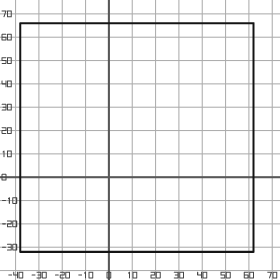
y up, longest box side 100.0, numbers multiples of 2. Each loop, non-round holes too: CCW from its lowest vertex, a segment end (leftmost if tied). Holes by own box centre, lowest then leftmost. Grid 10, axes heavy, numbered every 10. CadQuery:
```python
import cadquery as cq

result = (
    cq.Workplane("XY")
    .moveTo(-38.0, -32.0)
    .lineTo(62.0, -32.0)
    .lineTo(62.0, 66.0)
    .lineTo(-38.0, 66.0)
    .close()
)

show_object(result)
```